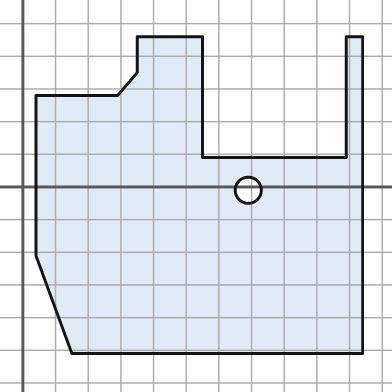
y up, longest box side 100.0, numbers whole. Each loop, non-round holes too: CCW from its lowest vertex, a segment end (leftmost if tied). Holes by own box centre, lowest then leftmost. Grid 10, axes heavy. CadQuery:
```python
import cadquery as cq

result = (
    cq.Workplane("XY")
    .moveTo(15.0, -51.0)
    .lineTo(104.0, -51.0)
    .lineTo(104.0, 46.0)
    .lineTo(99.0, 46.0)
    .lineTo(99.0, 9.0)
    .lineTo(55.0, 9.0)
    .lineTo(55.0, 46.0)
    .lineTo(35.0, 46.0)
    .lineTo(35.0, 35.0)
    .lineTo(29.0, 28.0)
    .lineTo(4.0, 28.0)
    .lineTo(4.0, -21.0)
    .close()
    .moveTo(69.0, -1.0)
    .circle(4.0)
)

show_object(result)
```